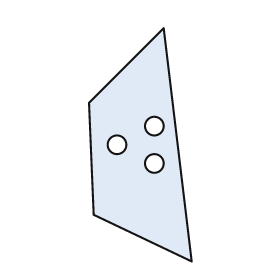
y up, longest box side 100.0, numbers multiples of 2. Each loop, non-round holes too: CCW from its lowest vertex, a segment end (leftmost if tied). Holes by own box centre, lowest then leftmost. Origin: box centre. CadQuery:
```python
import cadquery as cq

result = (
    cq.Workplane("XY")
    .moveTo(22.0, -50.0)
    .lineTo(10.0, 50.0)
    .lineTo(-22.0, 18.0)
    .lineTo(-20.0, -30.0)
    .close()
    .moveTo(6.0, -8.0)
    .circle(4.0)
    .moveTo(-10.0, 0.0)
    .circle(4.0)
    .moveTo(6.0, 8.0)
    .circle(4.0)
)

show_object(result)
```